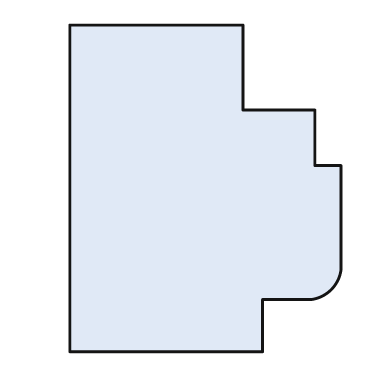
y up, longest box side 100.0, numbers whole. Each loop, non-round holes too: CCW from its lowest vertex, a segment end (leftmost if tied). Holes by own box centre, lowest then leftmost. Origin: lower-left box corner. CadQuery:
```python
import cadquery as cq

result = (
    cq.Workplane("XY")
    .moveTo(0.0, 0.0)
    .lineTo(59.0, 0.0)
    .lineTo(59.0, 16.0)
    .lineTo(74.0, 16.0)
    .threePointArc((80.0, 19.0), (83.0, 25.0))
    .lineTo(83.0, 57.0)
    .lineTo(75.0, 57.0)
    .lineTo(75.0, 74.0)
    .lineTo(53.0, 74.0)
    .lineTo(53.0, 100.0)
    .lineTo(0.0, 100.0)
    .close()
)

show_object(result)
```